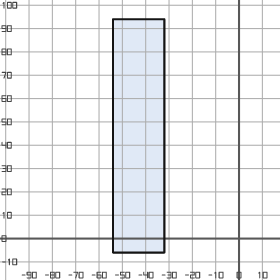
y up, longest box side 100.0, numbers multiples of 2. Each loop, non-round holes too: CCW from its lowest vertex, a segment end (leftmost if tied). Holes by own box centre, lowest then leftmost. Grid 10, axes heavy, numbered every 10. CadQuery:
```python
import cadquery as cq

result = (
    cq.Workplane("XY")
    .moveTo(-54.0, -6.0)
    .lineTo(-32.0, -6.0)
    .lineTo(-32.0, 94.0)
    .lineTo(-54.0, 94.0)
    .close()
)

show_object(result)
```